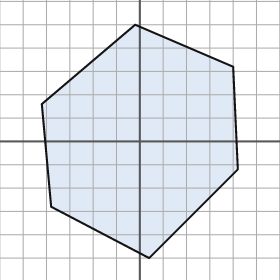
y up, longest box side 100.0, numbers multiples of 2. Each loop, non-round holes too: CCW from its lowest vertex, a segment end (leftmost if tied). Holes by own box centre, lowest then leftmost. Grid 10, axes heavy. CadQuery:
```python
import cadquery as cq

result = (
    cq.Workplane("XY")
    .moveTo(4.0, -50.0)
    .lineTo(42.0, -12.0)
    .lineTo(40.0, 32.0)
    .lineTo(-2.0, 50.0)
    .lineTo(-42.0, 16.0)
    .lineTo(-38.0, -28.0)
    .close()
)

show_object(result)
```